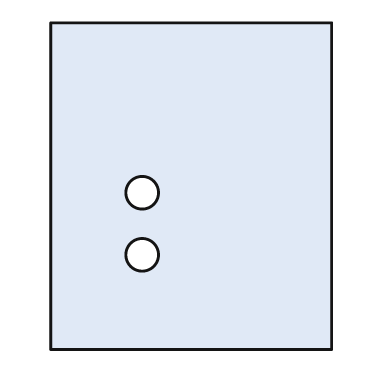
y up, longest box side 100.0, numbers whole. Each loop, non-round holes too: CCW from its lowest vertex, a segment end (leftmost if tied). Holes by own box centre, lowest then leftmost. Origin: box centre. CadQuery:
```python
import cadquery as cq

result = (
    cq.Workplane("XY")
    .moveTo(-43.0, -50.0)
    .lineTo(43.0, -50.0)
    .lineTo(43.0, 50.0)
    .lineTo(-43.0, 50.0)
    .close()
    .moveTo(-15.0, -21.0)
    .circle(5.0)
    .moveTo(-15.0, -2.0)
    .circle(5.0)
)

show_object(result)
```